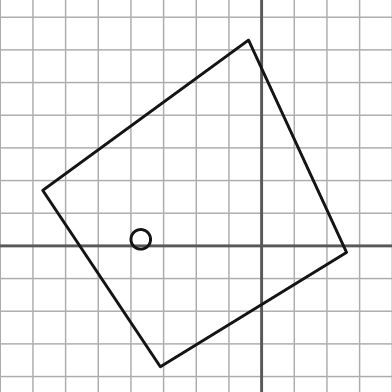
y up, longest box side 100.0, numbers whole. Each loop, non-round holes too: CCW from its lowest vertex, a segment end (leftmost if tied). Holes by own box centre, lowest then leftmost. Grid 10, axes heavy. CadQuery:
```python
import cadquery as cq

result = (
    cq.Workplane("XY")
    .moveTo(-31.0, -37.0)
    .lineTo(26.0, -2.0)
    .lineTo(-4.0, 63.0)
    .lineTo(-67.0, 17.0)
    .close()
    .moveTo(-37.0, 2.0)
    .circle(3.0)
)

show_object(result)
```